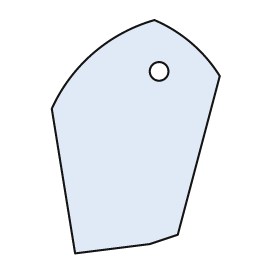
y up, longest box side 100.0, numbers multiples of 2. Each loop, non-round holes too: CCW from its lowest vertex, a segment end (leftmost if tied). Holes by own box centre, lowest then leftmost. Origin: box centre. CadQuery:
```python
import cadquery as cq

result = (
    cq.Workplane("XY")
    .moveTo(-26.0, -50.0)
    .lineTo(6.0, -46.0)
    .lineTo(18.0, -42.0)
    .lineTo(36.0, 26.0)
    .threePointArc((24.0, 40.0), (8.0, 50.0))
    .threePointArc((-18.0, 36.0), (-36.0, 12.0))
    .close()
    .moveTo(10.0, 28.0)
    .circle(4.0)
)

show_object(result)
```